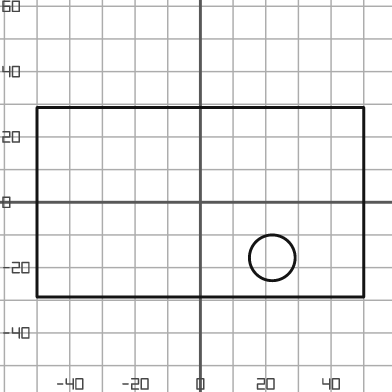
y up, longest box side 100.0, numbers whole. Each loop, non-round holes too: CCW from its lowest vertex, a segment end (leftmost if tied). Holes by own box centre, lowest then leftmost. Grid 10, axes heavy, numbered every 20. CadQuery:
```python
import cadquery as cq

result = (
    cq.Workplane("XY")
    .moveTo(-50.0, -29.0)
    .lineTo(50.0, -29.0)
    .lineTo(50.0, 29.0)
    .lineTo(-50.0, 29.0)
    .close()
    .moveTo(22.0, -17.0)
    .circle(7.0)
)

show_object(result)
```